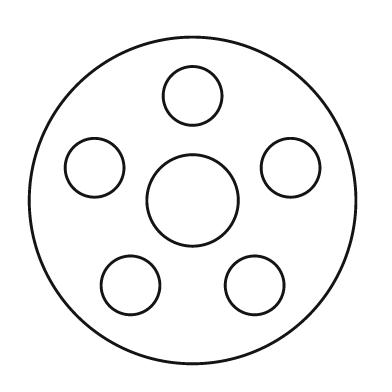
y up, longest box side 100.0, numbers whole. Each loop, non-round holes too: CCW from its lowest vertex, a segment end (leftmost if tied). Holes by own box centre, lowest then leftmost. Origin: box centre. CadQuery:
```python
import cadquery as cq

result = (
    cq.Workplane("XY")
    .moveTo(0.0, 0.0)
    .circle(50.0)
    .moveTo(-19.0, -26.0)
    .circle(9.0)
    .moveTo(19.0, -26.0)
    .circle(9.0)
    .moveTo(0.0, 0.0)
    .circle(14.0)
    .moveTo(-30.0, 10.0)
    .circle(9.0)
    .moveTo(30.0, 10.0)
    .circle(9.0)
    .moveTo(0.0, 32.0)
    .circle(9.0)
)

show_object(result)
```